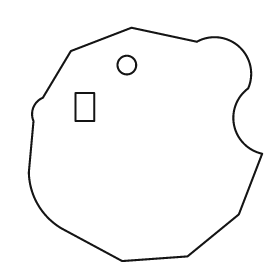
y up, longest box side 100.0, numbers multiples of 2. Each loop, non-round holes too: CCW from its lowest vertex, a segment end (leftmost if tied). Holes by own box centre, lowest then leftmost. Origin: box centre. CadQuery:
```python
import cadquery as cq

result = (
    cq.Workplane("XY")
    .moveTo(-10.0, -50.0)
    .lineTo(18.0, -48.0)
    .lineTo(40.0, -30.0)
    .lineTo(50.0, -4.0)
    .threePointArc((38.0, 8.0), (44.0, 24.0))
    .threePointArc((40.0, 42.0), (22.0, 44.0))
    .lineTo(-6.0, 50.0)
    .lineTo(-32.0, 40.0)
    .lineTo(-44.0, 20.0)
    .threePointArc((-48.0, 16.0), (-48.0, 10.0))
    .lineTo(-50.0, -12.0)
    .threePointArc((-46.0, -26.0), (-36.0, -36.0))
    .close()
    .moveTo(-30.0, 10.0)
    .lineTo(-22.0, 10.0)
    .lineTo(-22.0, 22.0)
    .lineTo(-30.0, 22.0)
    .close()
    .moveTo(-8.0, 34.0)
    .circle(4.0)
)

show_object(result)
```